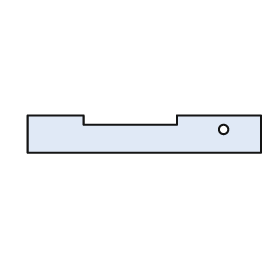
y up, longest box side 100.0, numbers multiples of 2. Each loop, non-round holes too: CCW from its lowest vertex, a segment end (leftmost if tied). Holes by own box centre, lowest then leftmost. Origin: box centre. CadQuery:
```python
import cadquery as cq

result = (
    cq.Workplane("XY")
    .moveTo(-50.0, -8.0)
    .lineTo(50.0, -8.0)
    .lineTo(50.0, 8.0)
    .lineTo(14.0, 8.0)
    .lineTo(14.0, 4.0)
    .lineTo(-26.0, 4.0)
    .lineTo(-26.0, 8.0)
    .lineTo(-50.0, 8.0)
    .close()
    .moveTo(34.0, 2.0)
    .circle(2.0)
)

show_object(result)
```